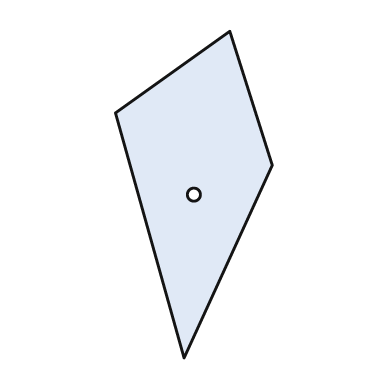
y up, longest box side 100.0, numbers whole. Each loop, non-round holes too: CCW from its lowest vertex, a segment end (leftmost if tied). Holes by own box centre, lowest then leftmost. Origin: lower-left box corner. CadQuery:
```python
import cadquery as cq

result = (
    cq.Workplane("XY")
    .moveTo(21.0, 0.0)
    .lineTo(48.0, 59.0)
    .lineTo(35.0, 100.0)
    .lineTo(0.0, 75.0)
    .close()
    .moveTo(24.0, 50.0)
    .circle(2.0)
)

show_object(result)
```